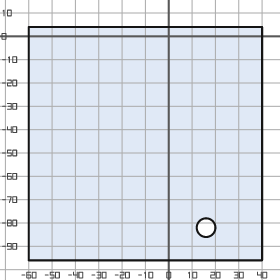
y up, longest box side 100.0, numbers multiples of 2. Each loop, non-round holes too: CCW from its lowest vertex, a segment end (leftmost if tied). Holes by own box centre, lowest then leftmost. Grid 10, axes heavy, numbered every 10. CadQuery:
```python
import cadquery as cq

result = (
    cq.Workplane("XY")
    .moveTo(-60.0, -96.0)
    .lineTo(40.0, -96.0)
    .lineTo(40.0, 4.0)
    .lineTo(-60.0, 4.0)
    .close()
    .moveTo(16.0, -82.0)
    .circle(4.0)
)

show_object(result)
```